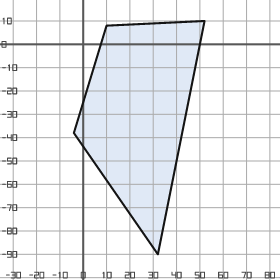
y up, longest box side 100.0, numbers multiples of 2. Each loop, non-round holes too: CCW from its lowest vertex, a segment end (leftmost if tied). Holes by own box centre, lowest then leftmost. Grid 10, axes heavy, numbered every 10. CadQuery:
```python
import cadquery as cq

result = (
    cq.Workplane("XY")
    .moveTo(32.0, -90.0)
    .lineTo(52.0, 10.0)
    .lineTo(10.0, 8.0)
    .lineTo(-4.0, -38.0)
    .close()
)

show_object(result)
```